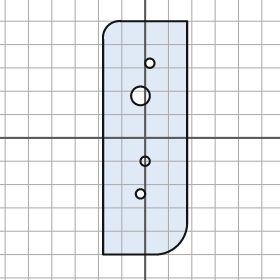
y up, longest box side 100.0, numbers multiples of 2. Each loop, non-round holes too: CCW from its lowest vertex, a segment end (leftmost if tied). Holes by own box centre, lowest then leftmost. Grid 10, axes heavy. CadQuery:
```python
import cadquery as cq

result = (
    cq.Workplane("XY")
    .moveTo(-18.0, -50.0)
    .lineTo(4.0, -50.0)
    .threePointArc((14.0, -46.0), (18.0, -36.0))
    .lineTo(18.0, 50.0)
    .lineTo(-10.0, 50.0)
    .threePointArc((-16.0, 48.0), (-18.0, 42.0))
    .close()
    .moveTo(-2.0, -24.0)
    .circle(2.0)
    .moveTo(0.0, -10.0)
    .circle(2.0)
    .moveTo(-2.0, 18.0)
    .circle(4.0)
    .moveTo(2.0, 32.0)
    .circle(2.0)
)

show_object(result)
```